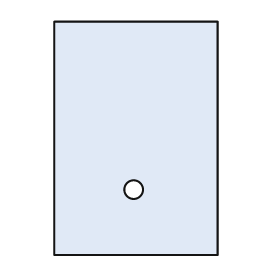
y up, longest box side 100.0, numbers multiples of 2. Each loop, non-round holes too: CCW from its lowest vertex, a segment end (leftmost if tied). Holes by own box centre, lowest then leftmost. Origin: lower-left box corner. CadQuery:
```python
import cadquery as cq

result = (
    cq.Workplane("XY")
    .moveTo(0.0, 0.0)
    .lineTo(70.0, 0.0)
    .lineTo(70.0, 100.0)
    .lineTo(0.0, 100.0)
    .close()
    .moveTo(34.0, 28.0)
    .circle(4.0)
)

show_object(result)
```